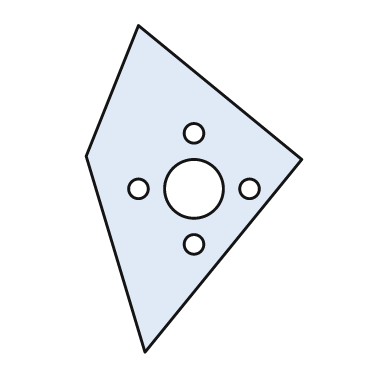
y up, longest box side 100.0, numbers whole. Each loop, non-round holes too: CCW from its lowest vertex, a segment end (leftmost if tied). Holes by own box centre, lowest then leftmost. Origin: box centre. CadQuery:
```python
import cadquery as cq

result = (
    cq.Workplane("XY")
    .moveTo(-15.0, -50.0)
    .lineTo(33.0, 9.0)
    .lineTo(-17.0, 50.0)
    .lineTo(-33.0, 10.0)
    .close()
    .moveTo(0.0, -17.0)
    .circle(3.0)
    .moveTo(-17.0, 0.0)
    .circle(3.0)
    .moveTo(0.0, 0.0)
    .circle(9.0)
    .moveTo(17.0, 0.0)
    .circle(3.0)
    .moveTo(0.0, 17.0)
    .circle(3.0)
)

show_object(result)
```